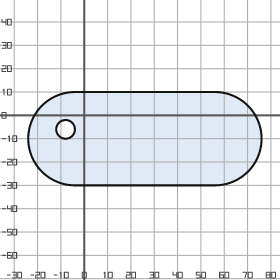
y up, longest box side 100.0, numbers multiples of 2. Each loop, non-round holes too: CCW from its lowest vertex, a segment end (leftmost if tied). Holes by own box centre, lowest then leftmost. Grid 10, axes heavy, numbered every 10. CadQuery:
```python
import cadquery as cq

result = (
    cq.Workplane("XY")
    .moveTo(-4.0, -30.0)
    .lineTo(56.0, -30.0)
    .threePointArc((76.0, -10.0), (56.0, 10.0))
    .lineTo(-4.0, 10.0)
    .threePointArc((-24.0, -10.0), (-4.0, -30.0))
    .close()
    .moveTo(-8.0, -6.0)
    .circle(4.0)
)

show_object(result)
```